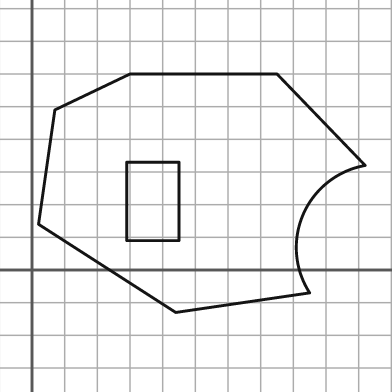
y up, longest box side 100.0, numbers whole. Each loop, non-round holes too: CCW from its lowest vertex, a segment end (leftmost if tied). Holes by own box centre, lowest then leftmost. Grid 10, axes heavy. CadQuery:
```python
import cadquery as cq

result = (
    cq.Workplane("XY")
    .moveTo(44.0, -13.0)
    .lineTo(85.0, -7.0)
    .threePointArc((83.0, 17.0), (102.0, 32.0))
    .lineTo(75.0, 60.0)
    .lineTo(30.0, 60.0)
    .lineTo(7.0, 49.0)
    .lineTo(2.0, 14.0)
    .close()
    .moveTo(29.0, 9.0)
    .lineTo(45.0, 9.0)
    .lineTo(45.0, 33.0)
    .lineTo(29.0, 33.0)
    .close()
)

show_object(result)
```